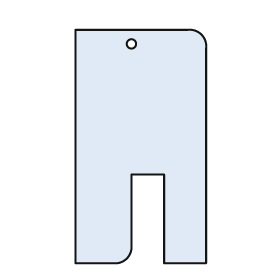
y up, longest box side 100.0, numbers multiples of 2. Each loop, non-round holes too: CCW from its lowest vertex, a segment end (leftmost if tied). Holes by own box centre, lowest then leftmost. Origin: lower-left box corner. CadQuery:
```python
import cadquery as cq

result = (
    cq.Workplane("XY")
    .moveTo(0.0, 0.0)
    .lineTo(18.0, 0.0)
    .threePointArc((22.0, 2.0), (24.0, 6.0))
    .lineTo(24.0, 38.0)
    .lineTo(38.0, 38.0)
    .lineTo(38.0, 0.0)
    .lineTo(56.0, 0.0)
    .lineTo(56.0, 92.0)
    .threePointArc((54.0, 98.0), (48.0, 100.0))
    .lineTo(0.0, 100.0)
    .close()
    .moveTo(24.0, 94.0)
    .circle(2.0)
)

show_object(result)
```